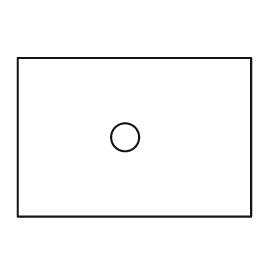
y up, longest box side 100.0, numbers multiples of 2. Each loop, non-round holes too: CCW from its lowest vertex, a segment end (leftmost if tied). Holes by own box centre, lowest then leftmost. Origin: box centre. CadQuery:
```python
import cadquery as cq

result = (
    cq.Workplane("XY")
    .moveTo(-50.0, -34.0)
    .lineTo(50.0, -34.0)
    .lineTo(50.0, 34.0)
    .lineTo(-50.0, 34.0)
    .close()
    .moveTo(-4.0, 0.0)
    .circle(6.0)
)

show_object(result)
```